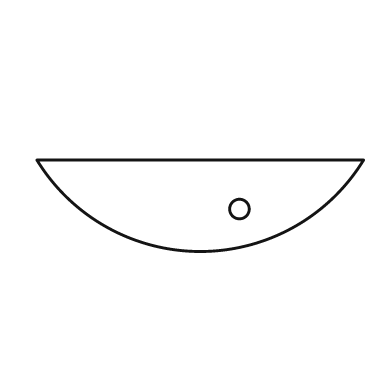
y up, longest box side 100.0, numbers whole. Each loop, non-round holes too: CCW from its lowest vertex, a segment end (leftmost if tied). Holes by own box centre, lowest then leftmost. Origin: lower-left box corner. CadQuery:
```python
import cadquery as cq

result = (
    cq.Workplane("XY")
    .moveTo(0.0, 28.0)
    .threePointArc((50.0, 0.0), (100.0, 28.0))
    .close()
    .moveTo(62.0, 13.0)
    .circle(3.0)
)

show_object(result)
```